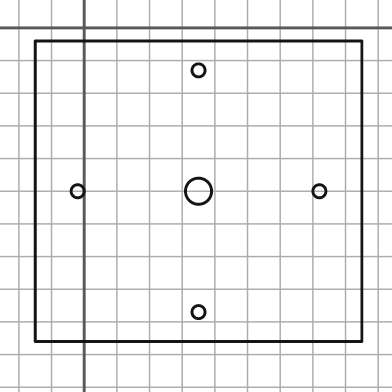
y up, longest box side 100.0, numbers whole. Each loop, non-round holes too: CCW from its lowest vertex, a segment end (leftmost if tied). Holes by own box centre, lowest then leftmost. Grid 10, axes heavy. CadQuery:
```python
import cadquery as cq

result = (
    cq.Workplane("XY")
    .moveTo(-15.0, -96.0)
    .lineTo(85.0, -96.0)
    .lineTo(85.0, -4.0)
    .lineTo(-15.0, -4.0)
    .close()
    .moveTo(35.0, -87.0)
    .circle(2.0)
    .moveTo(-2.0, -50.0)
    .circle(2.0)
    .moveTo(35.0, -50.0)
    .circle(4.0)
    .moveTo(72.0, -50.0)
    .circle(2.0)
    .moveTo(35.0, -13.0)
    .circle(2.0)
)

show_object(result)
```